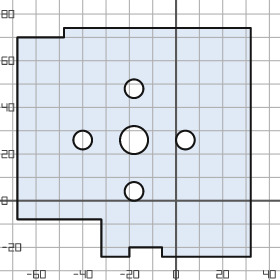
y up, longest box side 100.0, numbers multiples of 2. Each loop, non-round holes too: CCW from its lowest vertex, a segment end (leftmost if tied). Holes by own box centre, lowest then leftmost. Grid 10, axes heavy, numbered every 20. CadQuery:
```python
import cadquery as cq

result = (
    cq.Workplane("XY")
    .moveTo(-32.0, -24.0)
    .lineTo(-20.0, -24.0)
    .lineTo(-20.0, -20.0)
    .lineTo(-6.0, -20.0)
    .lineTo(-6.0, -24.0)
    .lineTo(32.0, -24.0)
    .lineTo(32.0, 74.0)
    .lineTo(-48.0, 74.0)
    .lineTo(-48.0, 70.0)
    .lineTo(-68.0, 70.0)
    .lineTo(-68.0, -8.0)
    .lineTo(-32.0, -8.0)
    .close()
    .moveTo(-18.0, 4.0)
    .circle(4.0)
    .moveTo(-40.0, 26.0)
    .circle(4.0)
    .moveTo(-18.0, 26.0)
    .circle(6.0)
    .moveTo(4.0, 26.0)
    .circle(4.0)
    .moveTo(-18.0, 48.0)
    .circle(4.0)
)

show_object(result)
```